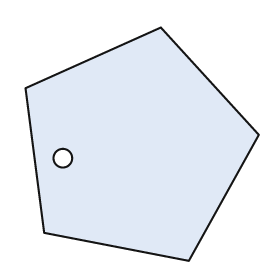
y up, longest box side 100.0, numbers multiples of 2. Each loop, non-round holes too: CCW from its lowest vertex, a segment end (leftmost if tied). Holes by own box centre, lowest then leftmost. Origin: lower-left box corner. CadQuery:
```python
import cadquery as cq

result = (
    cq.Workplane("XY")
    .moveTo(70.0, 0.0)
    .lineTo(100.0, 54.0)
    .lineTo(58.0, 100.0)
    .lineTo(0.0, 74.0)
    .lineTo(8.0, 12.0)
    .close()
    .moveTo(16.0, 44.0)
    .circle(4.0)
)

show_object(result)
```